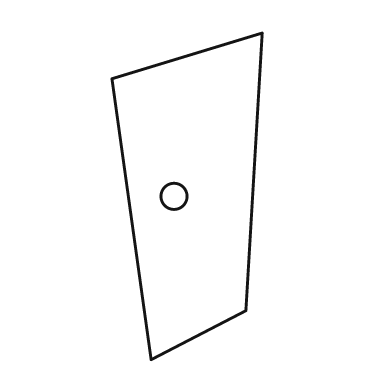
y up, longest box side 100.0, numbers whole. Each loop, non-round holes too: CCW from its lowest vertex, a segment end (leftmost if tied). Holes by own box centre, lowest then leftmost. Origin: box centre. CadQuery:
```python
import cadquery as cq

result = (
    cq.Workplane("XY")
    .moveTo(-11.0, -50.0)
    .lineTo(18.0, -35.0)
    .lineTo(23.0, 50.0)
    .lineTo(-23.0, 36.0)
    .close()
    .moveTo(-4.0, 0.0)
    .circle(4.0)
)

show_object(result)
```